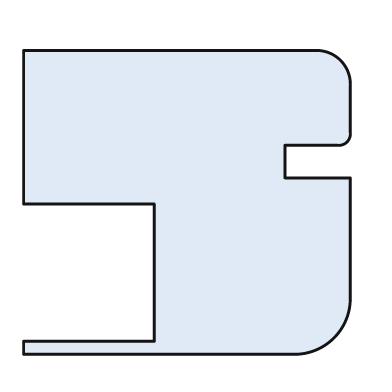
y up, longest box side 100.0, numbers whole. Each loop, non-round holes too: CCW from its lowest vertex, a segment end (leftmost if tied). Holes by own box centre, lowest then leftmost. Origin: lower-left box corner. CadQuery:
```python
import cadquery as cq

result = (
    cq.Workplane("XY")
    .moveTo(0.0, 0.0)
    .lineTo(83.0, 0.0)
    .threePointArc((95.0, 5.0), (100.0, 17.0))
    .lineTo(100.0, 54.0)
    .lineTo(80.0, 54.0)
    .lineTo(80.0, 64.0)
    .lineTo(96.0, 64.0)
    .threePointArc((99.0, 65.0), (100.0, 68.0))
    .lineTo(100.0, 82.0)
    .threePointArc((97.0, 90.0), (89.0, 93.0))
    .lineTo(0.0, 93.0)
    .lineTo(0.0, 46.0)
    .lineTo(40.0, 46.0)
    .lineTo(40.0, 4.0)
    .lineTo(0.0, 4.0)
    .close()
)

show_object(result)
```